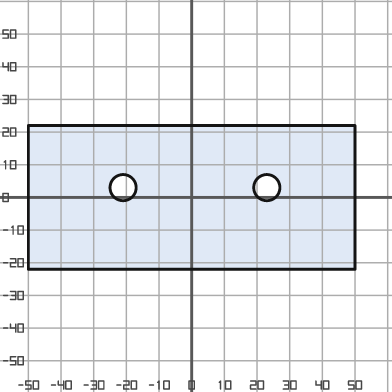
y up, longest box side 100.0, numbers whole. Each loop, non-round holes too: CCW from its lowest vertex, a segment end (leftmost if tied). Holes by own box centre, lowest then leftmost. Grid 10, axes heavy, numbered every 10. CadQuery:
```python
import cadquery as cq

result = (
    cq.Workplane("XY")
    .moveTo(-50.0, -22.0)
    .lineTo(50.0, -22.0)
    .lineTo(50.0, 22.0)
    .lineTo(-50.0, 22.0)
    .close()
    .moveTo(-21.0, 3.0)
    .circle(4.0)
    .moveTo(23.0, 3.0)
    .circle(4.0)
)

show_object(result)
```